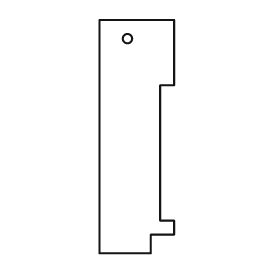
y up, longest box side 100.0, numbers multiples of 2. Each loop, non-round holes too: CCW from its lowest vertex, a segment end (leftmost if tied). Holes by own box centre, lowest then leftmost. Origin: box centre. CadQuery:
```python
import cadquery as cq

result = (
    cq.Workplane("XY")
    .moveTo(-16.0, -50.0)
    .lineTo(6.0, -50.0)
    .lineTo(6.0, -42.0)
    .lineTo(16.0, -42.0)
    .lineTo(16.0, -36.0)
    .lineTo(10.0, -36.0)
    .lineTo(10.0, 22.0)
    .lineTo(16.0, 22.0)
    .lineTo(16.0, 50.0)
    .lineTo(-16.0, 50.0)
    .close()
    .moveTo(-4.0, 42.0)
    .circle(2.0)
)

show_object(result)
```